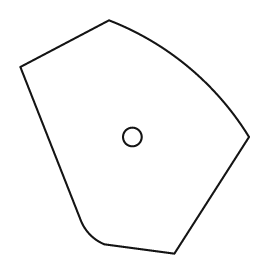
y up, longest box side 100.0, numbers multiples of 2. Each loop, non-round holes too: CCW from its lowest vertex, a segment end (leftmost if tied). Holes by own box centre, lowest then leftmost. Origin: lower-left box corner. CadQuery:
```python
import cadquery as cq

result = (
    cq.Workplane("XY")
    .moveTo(66.0, 0.0)
    .lineTo(98.0, 50.0)
    .threePointArc((72.0, 80.0), (38.0, 100.0))
    .lineTo(0.0, 80.0)
    .lineTo(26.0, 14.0)
    .threePointArc((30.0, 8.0), (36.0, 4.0))
    .close()
    .moveTo(48.0, 50.0)
    .circle(4.0)
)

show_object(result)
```